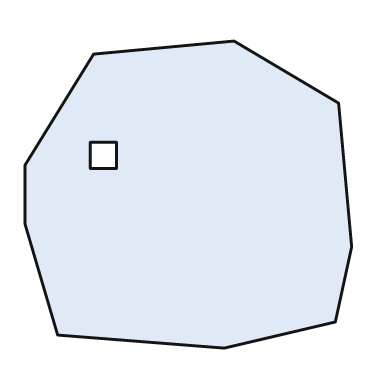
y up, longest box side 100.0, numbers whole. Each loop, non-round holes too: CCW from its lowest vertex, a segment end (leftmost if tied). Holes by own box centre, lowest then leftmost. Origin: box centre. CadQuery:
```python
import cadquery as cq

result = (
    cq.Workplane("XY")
    .moveTo(11.0, -47.0)
    .lineTo(45.0, -39.0)
    .lineTo(50.0, -16.0)
    .lineTo(46.0, 28.0)
    .lineTo(14.0, 47.0)
    .lineTo(-29.0, 43.0)
    .lineTo(-50.0, 9.0)
    .lineTo(-50.0, -9.0)
    .lineTo(-40.0, -43.0)
    .close()
    .moveTo(-30.0, 8.0)
    .lineTo(-22.0, 8.0)
    .lineTo(-22.0, 16.0)
    .lineTo(-30.0, 16.0)
    .close()
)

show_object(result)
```